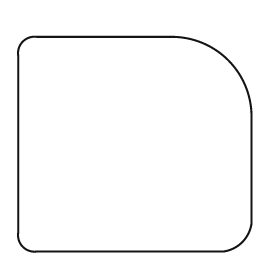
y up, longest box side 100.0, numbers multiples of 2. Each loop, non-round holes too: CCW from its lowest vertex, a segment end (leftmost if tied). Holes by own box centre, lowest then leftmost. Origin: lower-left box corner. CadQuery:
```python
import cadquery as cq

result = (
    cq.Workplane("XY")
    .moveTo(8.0, 0.0)
    .lineTo(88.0, 0.0)
    .threePointArc((96.0, 4.0), (100.0, 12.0))
    .lineTo(100.0, 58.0)
    .threePointArc((90.0, 82.0), (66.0, 92.0))
    .lineTo(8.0, 92.0)
    .threePointArc((2.0, 90.0), (0.0, 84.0))
    .lineTo(0.0, 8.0)
    .threePointArc((2.0, 2.0), (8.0, 0.0))
    .close()
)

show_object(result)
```